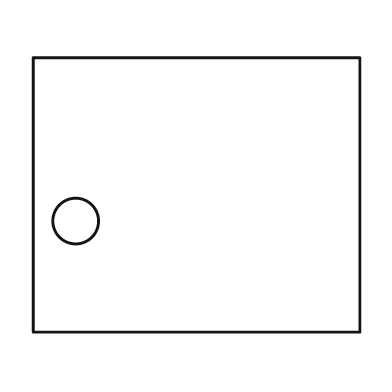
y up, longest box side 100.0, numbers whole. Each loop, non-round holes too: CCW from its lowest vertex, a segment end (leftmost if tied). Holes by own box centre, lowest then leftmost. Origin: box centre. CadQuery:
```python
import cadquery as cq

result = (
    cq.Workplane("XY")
    .moveTo(-50.0, -42.0)
    .lineTo(50.0, -42.0)
    .lineTo(50.0, 42.0)
    .lineTo(-50.0, 42.0)
    .close()
    .moveTo(-37.0, -8.0)
    .circle(7.0)
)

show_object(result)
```